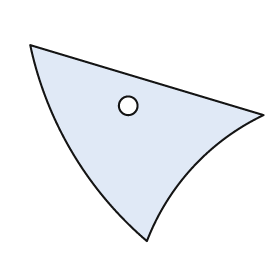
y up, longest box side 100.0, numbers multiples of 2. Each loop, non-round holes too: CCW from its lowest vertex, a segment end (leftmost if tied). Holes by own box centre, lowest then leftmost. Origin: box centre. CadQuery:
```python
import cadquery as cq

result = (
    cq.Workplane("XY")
    .moveTo(0.0, -42.0)
    .threePointArc((20.0, -10.0), (50.0, 12.0))
    .lineTo(-50.0, 42.0)
    .threePointArc((-32.0, -4.0), (0.0, -42.0))
    .close()
    .moveTo(-8.0, 16.0)
    .circle(4.0)
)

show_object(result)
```